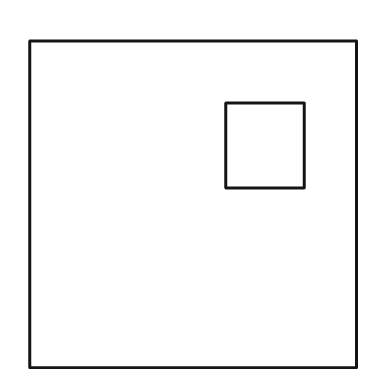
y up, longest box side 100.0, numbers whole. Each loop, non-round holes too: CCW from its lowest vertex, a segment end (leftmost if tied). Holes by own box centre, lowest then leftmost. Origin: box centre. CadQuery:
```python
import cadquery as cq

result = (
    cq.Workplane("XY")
    .moveTo(-50.0, -50.0)
    .lineTo(50.0, -50.0)
    .lineTo(50.0, 50.0)
    .lineTo(-50.0, 50.0)
    .close()
    .moveTo(10.0, 5.0)
    .lineTo(34.0, 5.0)
    .lineTo(34.0, 31.0)
    .lineTo(10.0, 31.0)
    .close()
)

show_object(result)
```